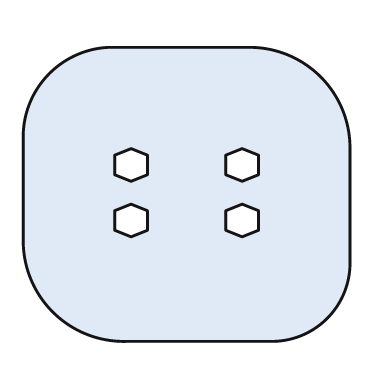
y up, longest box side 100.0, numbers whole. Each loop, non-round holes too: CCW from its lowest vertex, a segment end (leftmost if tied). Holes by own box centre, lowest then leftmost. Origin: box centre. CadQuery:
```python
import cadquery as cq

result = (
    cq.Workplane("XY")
    .moveTo(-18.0, -45.0)
    .lineTo(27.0, -45.0)
    .threePointArc((43.0, -38.0), (50.0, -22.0))
    .lineTo(50.0, 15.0)
    .threePointArc((41.0, 36.0), (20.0, 45.0))
    .lineTo(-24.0, 45.0)
    .threePointArc((-42.0, 37.0), (-50.0, 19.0))
    .lineTo(-50.0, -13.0)
    .threePointArc((-41.0, -36.0), (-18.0, -45.0))
    .close()
    .moveTo(-17.0, -13.0)
    .lineTo(-12.0, -11.0)
    .lineTo(-12.0, -5.0)
    .lineTo(-17.0, -3.0)
    .lineTo(-22.0, -5.0)
    .lineTo(-22.0, -11.0)
    .close()
    .moveTo(17.0, -13.0)
    .lineTo(22.0, -11.0)
    .lineTo(22.0, -5.0)
    .lineTo(17.0, -3.0)
    .lineTo(12.0, -5.0)
    .lineTo(12.0, -11.0)
    .close()
    .moveTo(-17.0, 4.0)
    .lineTo(-12.0, 6.0)
    .lineTo(-12.0, 12.0)
    .lineTo(-17.0, 14.0)
    .lineTo(-22.0, 12.0)
    .lineTo(-22.0, 6.0)
    .close()
    .moveTo(17.0, 4.0)
    .lineTo(22.0, 6.0)
    .lineTo(22.0, 12.0)
    .lineTo(17.0, 14.0)
    .lineTo(12.0, 12.0)
    .lineTo(12.0, 6.0)
    .close()
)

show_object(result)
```